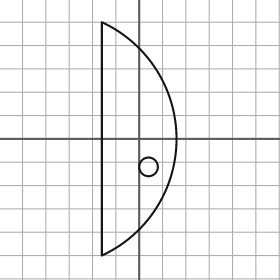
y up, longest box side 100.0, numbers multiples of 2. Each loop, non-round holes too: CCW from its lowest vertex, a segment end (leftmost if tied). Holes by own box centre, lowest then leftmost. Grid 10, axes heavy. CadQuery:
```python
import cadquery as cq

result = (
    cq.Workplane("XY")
    .moveTo(-16.0, -50.0)
    .threePointArc((16.0, 0.0), (-16.0, 50.0))
    .close()
    .moveTo(4.0, -12.0)
    .circle(4.0)
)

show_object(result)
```